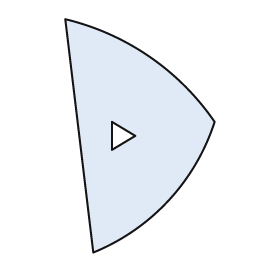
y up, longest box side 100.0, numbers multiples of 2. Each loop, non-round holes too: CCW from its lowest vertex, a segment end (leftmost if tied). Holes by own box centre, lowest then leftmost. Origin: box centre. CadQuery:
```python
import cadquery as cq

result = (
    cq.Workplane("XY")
    .moveTo(-20.0, -50.0)
    .threePointArc((12.0, -28.0), (32.0, 6.0))
    .threePointArc((4.0, 34.0), (-32.0, 50.0))
    .close()
    .moveTo(-12.0, -6.0)
    .lineTo(-2.0, 0.0)
    .lineTo(-12.0, 6.0)
    .close()
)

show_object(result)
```